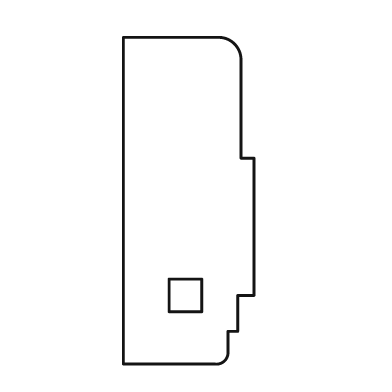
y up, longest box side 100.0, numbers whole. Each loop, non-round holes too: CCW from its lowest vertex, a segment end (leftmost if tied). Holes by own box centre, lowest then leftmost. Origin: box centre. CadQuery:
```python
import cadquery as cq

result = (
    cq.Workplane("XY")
    .moveTo(-20.0, -50.0)
    .lineTo(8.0, -50.0)
    .threePointArc((11.0, -49.0), (12.0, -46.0))
    .lineTo(12.0, -40.0)
    .lineTo(15.0, -40.0)
    .lineTo(15.0, -29.0)
    .lineTo(20.0, -29.0)
    .lineTo(20.0, 13.0)
    .lineTo(16.0, 13.0)
    .lineTo(16.0, 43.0)
    .threePointArc((14.0, 48.0), (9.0, 50.0))
    .lineTo(-20.0, 50.0)
    .close()
    .moveTo(-6.0, -34.0)
    .lineTo(4.0, -34.0)
    .lineTo(4.0, -24.0)
    .lineTo(-6.0, -24.0)
    .close()
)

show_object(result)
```